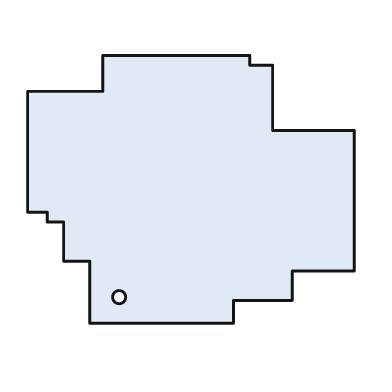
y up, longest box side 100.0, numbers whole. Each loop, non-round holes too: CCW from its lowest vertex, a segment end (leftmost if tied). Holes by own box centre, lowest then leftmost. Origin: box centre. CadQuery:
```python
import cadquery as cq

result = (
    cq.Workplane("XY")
    .moveTo(-31.0, -41.0)
    .lineTo(13.0, -41.0)
    .lineTo(13.0, -34.0)
    .lineTo(31.0, -34.0)
    .lineTo(31.0, -25.0)
    .lineTo(50.0, -25.0)
    .lineTo(50.0, 18.0)
    .lineTo(25.0, 18.0)
    .lineTo(25.0, 38.0)
    .lineTo(18.0, 38.0)
    .lineTo(18.0, 41.0)
    .lineTo(-27.0, 41.0)
    .lineTo(-27.0, 30.0)
    .lineTo(-50.0, 30.0)
    .lineTo(-50.0, -7.0)
    .lineTo(-44.0, -7.0)
    .lineTo(-44.0, -10.0)
    .lineTo(-39.0, -10.0)
    .lineTo(-39.0, -22.0)
    .lineTo(-31.0, -22.0)
    .close()
    .moveTo(-22.0, -33.0)
    .circle(2.0)
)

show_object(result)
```